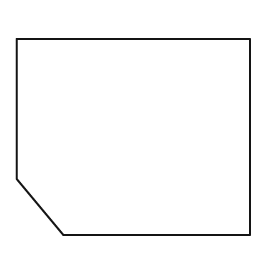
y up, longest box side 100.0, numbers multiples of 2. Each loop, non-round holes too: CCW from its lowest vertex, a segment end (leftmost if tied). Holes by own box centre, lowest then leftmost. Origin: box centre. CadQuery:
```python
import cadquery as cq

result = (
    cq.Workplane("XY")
    .moveTo(-30.0, -42.0)
    .lineTo(50.0, -42.0)
    .lineTo(50.0, 42.0)
    .lineTo(-50.0, 42.0)
    .lineTo(-50.0, -18.0)
    .close()
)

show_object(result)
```